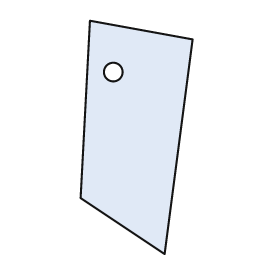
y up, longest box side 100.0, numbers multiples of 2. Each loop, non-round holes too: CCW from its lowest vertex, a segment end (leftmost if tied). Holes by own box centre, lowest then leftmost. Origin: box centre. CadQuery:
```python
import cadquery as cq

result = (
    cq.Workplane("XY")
    .moveTo(12.0, -50.0)
    .lineTo(24.0, 42.0)
    .lineTo(-20.0, 50.0)
    .lineTo(-24.0, -26.0)
    .close()
    .moveTo(-10.0, 28.0)
    .circle(4.0)
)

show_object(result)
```